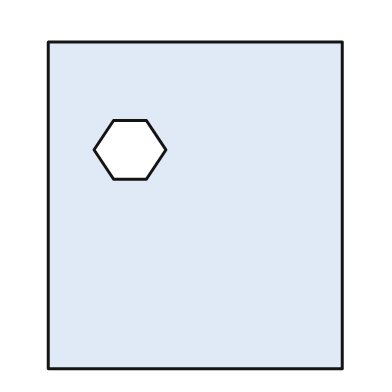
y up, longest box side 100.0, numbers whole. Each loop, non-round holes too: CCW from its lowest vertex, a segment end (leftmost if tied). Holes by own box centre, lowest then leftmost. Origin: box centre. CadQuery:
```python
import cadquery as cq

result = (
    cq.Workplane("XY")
    .moveTo(-45.0, -50.0)
    .lineTo(45.0, -50.0)
    .lineTo(45.0, 50.0)
    .lineTo(-45.0, 50.0)
    .close()
    .moveTo(-25.0, 8.0)
    .lineTo(-15.0, 8.0)
    .lineTo(-9.0, 17.0)
    .lineTo(-15.0, 26.0)
    .lineTo(-25.0, 26.0)
    .lineTo(-31.0, 17.0)
    .close()
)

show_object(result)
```